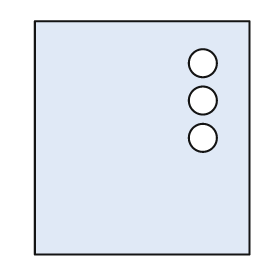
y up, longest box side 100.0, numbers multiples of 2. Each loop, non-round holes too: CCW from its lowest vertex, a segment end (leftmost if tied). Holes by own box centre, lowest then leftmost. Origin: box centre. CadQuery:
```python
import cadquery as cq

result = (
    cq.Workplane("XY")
    .moveTo(-46.0, -50.0)
    .lineTo(46.0, -50.0)
    .lineTo(46.0, 50.0)
    .lineTo(-46.0, 50.0)
    .close()
    .moveTo(26.0, 0.0)
    .circle(6.0)
    .moveTo(26.0, 16.0)
    .circle(6.0)
    .moveTo(26.0, 32.0)
    .circle(6.0)
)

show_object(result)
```